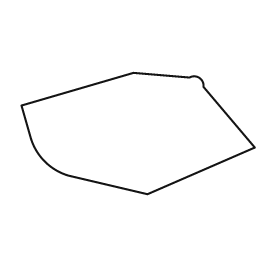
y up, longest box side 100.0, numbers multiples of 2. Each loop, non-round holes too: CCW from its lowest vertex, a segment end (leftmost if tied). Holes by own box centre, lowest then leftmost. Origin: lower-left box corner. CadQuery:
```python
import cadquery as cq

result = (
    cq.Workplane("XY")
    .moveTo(54.0, 0.0)
    .lineTo(100.0, 20.0)
    .lineTo(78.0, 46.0)
    .threePointArc((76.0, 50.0), (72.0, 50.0))
    .lineTo(48.0, 52.0)
    .lineTo(0.0, 38.0)
    .lineTo(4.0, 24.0)
    .threePointArc((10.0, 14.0), (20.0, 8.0))
    .close()
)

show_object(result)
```